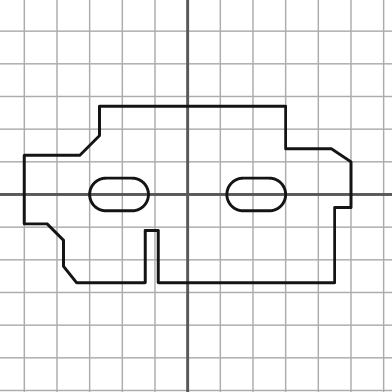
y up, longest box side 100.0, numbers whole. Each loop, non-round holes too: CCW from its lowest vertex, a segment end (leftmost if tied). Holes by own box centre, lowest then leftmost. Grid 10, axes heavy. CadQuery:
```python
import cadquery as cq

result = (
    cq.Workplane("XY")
    .moveTo(-34.0, -27.0)
    .lineTo(-13.0, -27.0)
    .lineTo(-13.0, -11.0)
    .lineTo(-9.0, -11.0)
    .lineTo(-9.0, -27.0)
    .lineTo(45.0, -27.0)
    .lineTo(45.0, -4.0)
    .lineTo(50.0, -4.0)
    .lineTo(50.0, 10.0)
    .lineTo(44.0, 14.0)
    .lineTo(30.0, 14.0)
    .lineTo(30.0, 27.0)
    .lineTo(-27.0, 27.0)
    .lineTo(-27.0, 18.0)
    .lineTo(-33.0, 12.0)
    .lineTo(-50.0, 12.0)
    .lineTo(-50.0, -9.0)
    .lineTo(-43.0, -9.0)
    .lineTo(-38.0, -14.0)
    .lineTo(-38.0, -22.0)
    .close()
    .moveTo(-25.0, -5.0)
    .lineTo(-17.0, -5.0)
    .threePointArc((-12.0, 0.0), (-17.0, 5.0))
    .lineTo(-25.0, 5.0)
    .threePointArc((-30.0, 0.0), (-25.0, -5.0))
    .close()
    .moveTo(17.0, -5.0)
    .lineTo(25.0, -5.0)
    .threePointArc((30.0, 0.0), (25.0, 5.0))
    .lineTo(17.0, 5.0)
    .threePointArc((12.0, 0.0), (17.0, -5.0))
    .close()
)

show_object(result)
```